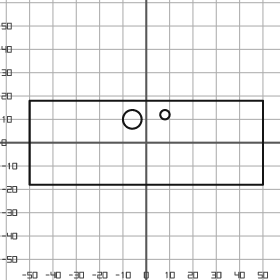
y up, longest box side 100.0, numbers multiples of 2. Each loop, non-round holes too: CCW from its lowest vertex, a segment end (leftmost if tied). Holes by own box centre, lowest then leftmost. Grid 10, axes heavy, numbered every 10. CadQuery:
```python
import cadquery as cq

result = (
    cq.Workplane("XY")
    .moveTo(-50.0, -18.0)
    .lineTo(50.0, -18.0)
    .lineTo(50.0, 18.0)
    .lineTo(-50.0, 18.0)
    .close()
    .moveTo(-6.0, 10.0)
    .circle(4.0)
    .moveTo(8.0, 12.0)
    .circle(2.0)
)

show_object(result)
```